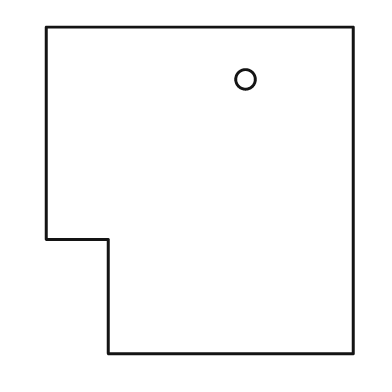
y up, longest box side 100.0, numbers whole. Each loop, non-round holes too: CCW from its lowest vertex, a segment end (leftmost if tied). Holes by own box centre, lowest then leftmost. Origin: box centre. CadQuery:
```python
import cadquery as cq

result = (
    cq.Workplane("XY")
    .moveTo(-28.0, -50.0)
    .lineTo(47.0, -50.0)
    .lineTo(47.0, 50.0)
    .lineTo(-47.0, 50.0)
    .lineTo(-47.0, -15.0)
    .lineTo(-28.0, -15.0)
    .close()
    .moveTo(14.0, 34.0)
    .circle(3.0)
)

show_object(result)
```